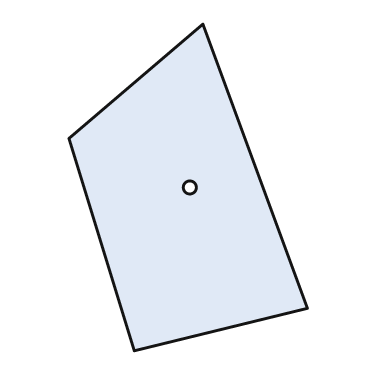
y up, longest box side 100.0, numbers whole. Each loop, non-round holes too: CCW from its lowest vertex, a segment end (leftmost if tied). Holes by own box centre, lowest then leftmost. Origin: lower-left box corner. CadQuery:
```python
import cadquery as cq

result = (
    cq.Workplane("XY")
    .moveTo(20.0, 0.0)
    .lineTo(73.0, 13.0)
    .lineTo(41.0, 100.0)
    .lineTo(0.0, 65.0)
    .close()
    .moveTo(37.0, 50.0)
    .circle(2.0)
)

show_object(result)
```